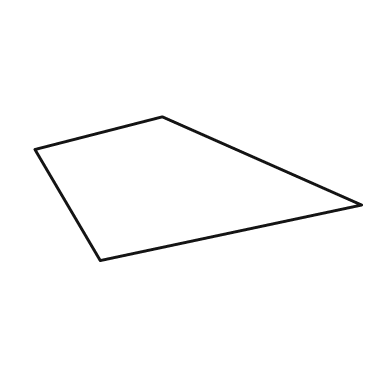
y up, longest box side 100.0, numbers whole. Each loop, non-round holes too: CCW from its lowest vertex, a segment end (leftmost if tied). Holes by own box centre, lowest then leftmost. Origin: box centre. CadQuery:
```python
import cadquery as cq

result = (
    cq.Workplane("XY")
    .moveTo(-30.0, -22.0)
    .lineTo(50.0, -5.0)
    .lineTo(-11.0, 22.0)
    .lineTo(-50.0, 12.0)
    .close()
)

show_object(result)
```